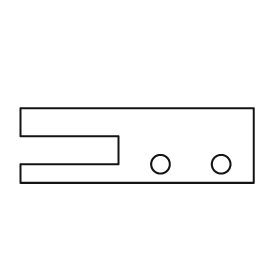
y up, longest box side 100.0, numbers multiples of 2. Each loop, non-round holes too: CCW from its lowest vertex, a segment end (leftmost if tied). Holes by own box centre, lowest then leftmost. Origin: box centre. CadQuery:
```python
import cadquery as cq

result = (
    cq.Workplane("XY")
    .moveTo(-50.0, -16.0)
    .lineTo(50.0, -16.0)
    .lineTo(50.0, 16.0)
    .lineTo(-50.0, 16.0)
    .lineTo(-50.0, 4.0)
    .lineTo(-8.0, 4.0)
    .lineTo(-8.0, -8.0)
    .lineTo(-50.0, -8.0)
    .close()
    .moveTo(10.0, -8.0)
    .circle(4.0)
    .moveTo(36.0, -8.0)
    .circle(4.0)
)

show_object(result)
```